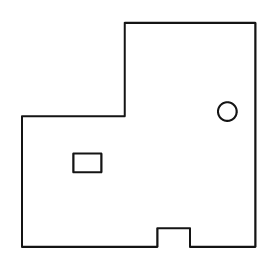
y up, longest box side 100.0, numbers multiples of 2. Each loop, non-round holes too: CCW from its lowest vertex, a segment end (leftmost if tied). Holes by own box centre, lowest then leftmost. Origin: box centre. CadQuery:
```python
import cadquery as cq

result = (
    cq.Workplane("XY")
    .moveTo(-50.0, -48.0)
    .lineTo(8.0, -48.0)
    .lineTo(8.0, -40.0)
    .lineTo(22.0, -40.0)
    .lineTo(22.0, -48.0)
    .lineTo(50.0, -48.0)
    .lineTo(50.0, 48.0)
    .lineTo(-6.0, 48.0)
    .lineTo(-6.0, 8.0)
    .lineTo(-50.0, 8.0)
    .close()
    .moveTo(-28.0, -16.0)
    .lineTo(-16.0, -16.0)
    .lineTo(-16.0, -8.0)
    .lineTo(-28.0, -8.0)
    .close()
    .moveTo(38.0, 10.0)
    .circle(4.0)
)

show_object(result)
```